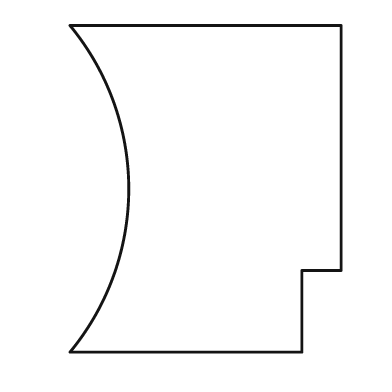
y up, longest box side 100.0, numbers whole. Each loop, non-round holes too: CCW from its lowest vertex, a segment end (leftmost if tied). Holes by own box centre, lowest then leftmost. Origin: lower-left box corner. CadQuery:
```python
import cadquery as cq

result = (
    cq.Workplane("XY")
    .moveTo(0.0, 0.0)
    .lineTo(71.0, 0.0)
    .lineTo(71.0, 25.0)
    .lineTo(83.0, 25.0)
    .lineTo(83.0, 100.0)
    .lineTo(0.0, 100.0)
    .threePointArc((18.0, 50.0), (0.0, 0.0))
    .close()
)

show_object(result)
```